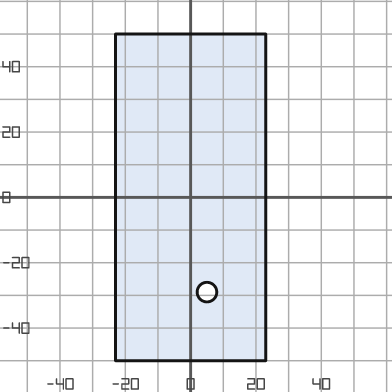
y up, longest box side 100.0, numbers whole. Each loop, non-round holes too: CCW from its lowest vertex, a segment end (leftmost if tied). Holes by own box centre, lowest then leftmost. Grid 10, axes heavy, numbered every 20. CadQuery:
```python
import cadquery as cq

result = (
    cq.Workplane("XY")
    .moveTo(-23.0, -50.0)
    .lineTo(23.0, -50.0)
    .lineTo(23.0, 50.0)
    .lineTo(-23.0, 50.0)
    .close()
    .moveTo(5.0, -29.0)
    .circle(3.0)
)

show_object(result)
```